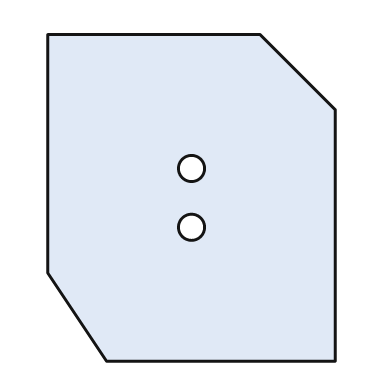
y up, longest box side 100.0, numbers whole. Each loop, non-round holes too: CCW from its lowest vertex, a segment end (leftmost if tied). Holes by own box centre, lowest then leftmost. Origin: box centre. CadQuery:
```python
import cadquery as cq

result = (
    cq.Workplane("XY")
    .moveTo(-26.0, -50.0)
    .lineTo(44.0, -50.0)
    .lineTo(44.0, 27.0)
    .lineTo(21.0, 50.0)
    .lineTo(-44.0, 50.0)
    .lineTo(-44.0, -23.0)
    .close()
    .moveTo(0.0, -9.0)
    .circle(4.0)
    .moveTo(0.0, 9.0)
    .circle(4.0)
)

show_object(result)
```